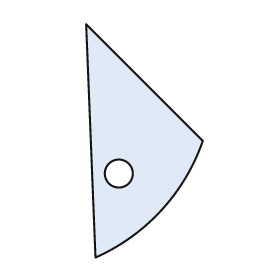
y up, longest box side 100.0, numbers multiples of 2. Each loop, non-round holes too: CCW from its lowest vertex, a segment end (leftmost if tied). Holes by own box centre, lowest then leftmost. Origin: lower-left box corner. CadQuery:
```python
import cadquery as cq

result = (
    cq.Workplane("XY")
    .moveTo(4.0, 0.0)
    .threePointArc((32.0, 20.0), (50.0, 50.0))
    .lineTo(0.0, 100.0)
    .close()
    .moveTo(14.0, 36.0)
    .circle(6.0)
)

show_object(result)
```